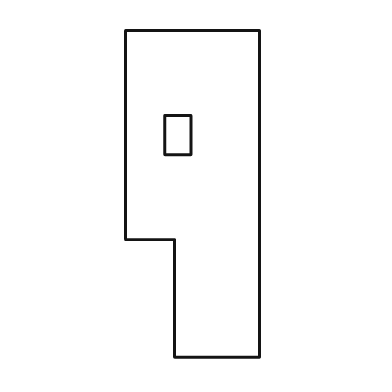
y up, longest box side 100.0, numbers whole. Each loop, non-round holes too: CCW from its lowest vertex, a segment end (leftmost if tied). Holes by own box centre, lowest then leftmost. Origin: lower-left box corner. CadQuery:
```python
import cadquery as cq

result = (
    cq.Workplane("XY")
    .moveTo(15.0, 0.0)
    .lineTo(41.0, 0.0)
    .lineTo(41.0, 100.0)
    .lineTo(0.0, 100.0)
    .lineTo(0.0, 36.0)
    .lineTo(15.0, 36.0)
    .close()
    .moveTo(12.0, 62.0)
    .lineTo(20.0, 62.0)
    .lineTo(20.0, 74.0)
    .lineTo(12.0, 74.0)
    .close()
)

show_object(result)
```